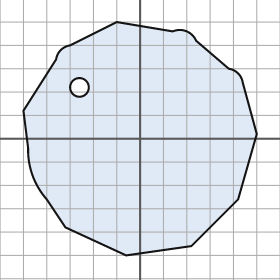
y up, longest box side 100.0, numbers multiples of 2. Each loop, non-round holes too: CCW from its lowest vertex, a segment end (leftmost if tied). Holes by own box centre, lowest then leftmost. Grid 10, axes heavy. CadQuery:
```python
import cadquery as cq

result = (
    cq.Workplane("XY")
    .moveTo(-6.0, -50.0)
    .lineTo(22.0, -46.0)
    .lineTo(42.0, -26.0)
    .lineTo(50.0, 2.0)
    .lineTo(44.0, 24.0)
    .threePointArc((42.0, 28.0), (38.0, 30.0))
    .lineTo(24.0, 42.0)
    .threePointArc((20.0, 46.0), (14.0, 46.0))
    .lineTo(-10.0, 50.0)
    .lineTo(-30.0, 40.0)
    .threePointArc((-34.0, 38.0), (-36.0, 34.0))
    .lineTo(-50.0, 12.0)
    .lineTo(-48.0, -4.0)
    .threePointArc((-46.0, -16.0), (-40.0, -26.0))
    .lineTo(-32.0, -38.0)
    .close()
    .moveTo(-26.0, 22.0)
    .circle(4.0)
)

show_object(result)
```